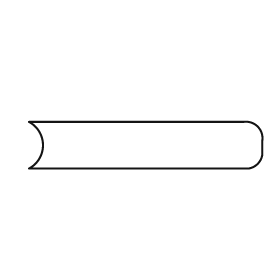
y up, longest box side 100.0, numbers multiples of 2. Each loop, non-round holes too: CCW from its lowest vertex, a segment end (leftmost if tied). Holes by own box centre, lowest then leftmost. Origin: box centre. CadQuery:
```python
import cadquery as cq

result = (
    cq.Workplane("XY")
    .moveTo(-50.0, -10.0)
    .lineTo(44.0, -10.0)
    .threePointArc((48.0, -8.0), (50.0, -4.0))
    .lineTo(50.0, 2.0)
    .threePointArc((48.0, 8.0), (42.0, 10.0))
    .lineTo(-50.0, 10.0)
    .threePointArc((-44.0, 0.0), (-50.0, -10.0))
    .close()
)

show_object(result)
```